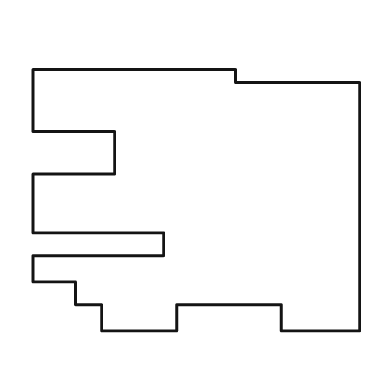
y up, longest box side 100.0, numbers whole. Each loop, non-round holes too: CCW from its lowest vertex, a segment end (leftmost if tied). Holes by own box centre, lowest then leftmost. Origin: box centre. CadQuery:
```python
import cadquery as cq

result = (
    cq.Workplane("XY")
    .moveTo(-29.0, -40.0)
    .lineTo(-6.0, -40.0)
    .lineTo(-6.0, -32.0)
    .lineTo(26.0, -32.0)
    .lineTo(26.0, -40.0)
    .lineTo(50.0, -40.0)
    .lineTo(50.0, 36.0)
    .lineTo(12.0, 36.0)
    .lineTo(12.0, 40.0)
    .lineTo(-50.0, 40.0)
    .lineTo(-50.0, 21.0)
    .lineTo(-25.0, 21.0)
    .lineTo(-25.0, 8.0)
    .lineTo(-50.0, 8.0)
    .lineTo(-50.0, -10.0)
    .lineTo(-10.0, -10.0)
    .lineTo(-10.0, -17.0)
    .lineTo(-50.0, -17.0)
    .lineTo(-50.0, -25.0)
    .lineTo(-37.0, -25.0)
    .lineTo(-37.0, -32.0)
    .lineTo(-29.0, -32.0)
    .close()
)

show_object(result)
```